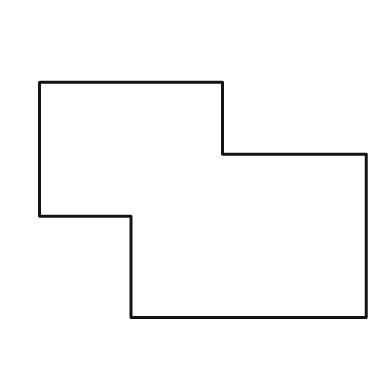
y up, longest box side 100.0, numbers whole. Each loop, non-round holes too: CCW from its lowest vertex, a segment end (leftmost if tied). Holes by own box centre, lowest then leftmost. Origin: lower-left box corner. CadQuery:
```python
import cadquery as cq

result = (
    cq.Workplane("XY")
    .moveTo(28.0, 0.0)
    .lineTo(100.0, 0.0)
    .lineTo(100.0, 50.0)
    .lineTo(56.0, 50.0)
    .lineTo(56.0, 72.0)
    .lineTo(0.0, 72.0)
    .lineTo(0.0, 31.0)
    .lineTo(28.0, 31.0)
    .close()
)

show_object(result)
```